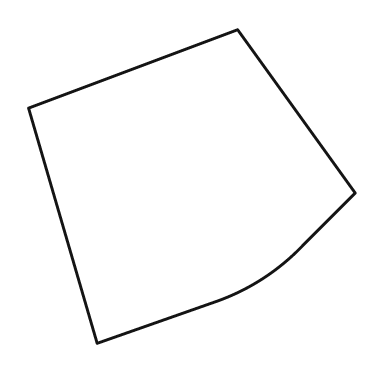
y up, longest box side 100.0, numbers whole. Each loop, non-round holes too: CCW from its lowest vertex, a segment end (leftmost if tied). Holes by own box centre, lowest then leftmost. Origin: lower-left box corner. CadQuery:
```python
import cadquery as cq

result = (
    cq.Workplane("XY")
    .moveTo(21.0, 0.0)
    .lineTo(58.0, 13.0)
    .threePointArc((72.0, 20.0), (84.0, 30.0))
    .lineTo(100.0, 46.0)
    .lineTo(64.0, 96.0)
    .lineTo(0.0, 72.0)
    .close()
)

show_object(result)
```